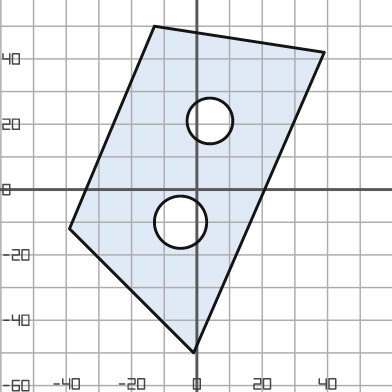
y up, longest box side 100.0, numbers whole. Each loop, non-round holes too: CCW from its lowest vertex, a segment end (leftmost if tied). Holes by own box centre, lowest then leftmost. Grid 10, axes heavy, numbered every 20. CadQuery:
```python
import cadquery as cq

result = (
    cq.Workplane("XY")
    .moveTo(-1.0, -50.0)
    .lineTo(39.0, 42.0)
    .lineTo(-13.0, 50.0)
    .lineTo(-39.0, -12.0)
    .close()
    .moveTo(-5.0, -10.0)
    .circle(8.0)
    .moveTo(4.0, 21.0)
    .circle(7.0)
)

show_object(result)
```